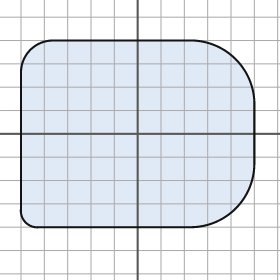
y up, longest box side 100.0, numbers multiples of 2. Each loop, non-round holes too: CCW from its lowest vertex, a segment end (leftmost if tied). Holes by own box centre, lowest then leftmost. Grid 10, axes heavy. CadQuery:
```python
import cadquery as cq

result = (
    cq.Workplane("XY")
    .moveTo(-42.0, -40.0)
    .lineTo(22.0, -40.0)
    .threePointArc((42.0, -32.0), (50.0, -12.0))
    .lineTo(50.0, 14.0)
    .threePointArc((42.0, 32.0), (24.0, 40.0))
    .lineTo(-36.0, 40.0)
    .threePointArc((-46.0, 36.0), (-50.0, 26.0))
    .lineTo(-50.0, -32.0)
    .threePointArc((-48.0, -38.0), (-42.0, -40.0))
    .close()
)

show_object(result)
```